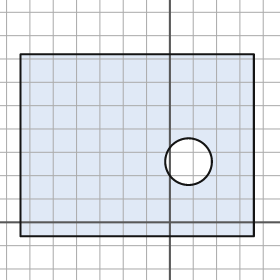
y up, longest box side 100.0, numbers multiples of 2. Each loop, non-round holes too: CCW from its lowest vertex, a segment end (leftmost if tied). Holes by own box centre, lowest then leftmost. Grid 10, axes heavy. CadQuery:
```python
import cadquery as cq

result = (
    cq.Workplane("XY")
    .moveTo(-64.0, -6.0)
    .lineTo(36.0, -6.0)
    .lineTo(36.0, 72.0)
    .lineTo(-64.0, 72.0)
    .close()
    .moveTo(8.0, 26.0)
    .circle(10.0)
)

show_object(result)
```